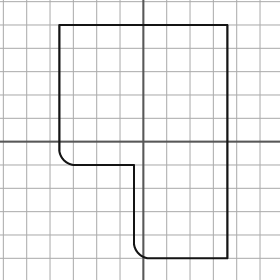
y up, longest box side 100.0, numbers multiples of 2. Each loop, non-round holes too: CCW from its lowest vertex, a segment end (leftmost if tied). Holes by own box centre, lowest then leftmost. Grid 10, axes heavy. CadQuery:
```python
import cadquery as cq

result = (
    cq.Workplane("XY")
    .moveTo(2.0, -50.0)
    .lineTo(36.0, -50.0)
    .lineTo(36.0, 50.0)
    .lineTo(-36.0, 50.0)
    .lineTo(-36.0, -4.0)
    .threePointArc((-34.0, -8.0), (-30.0, -10.0))
    .lineTo(-4.0, -10.0)
    .lineTo(-4.0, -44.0)
    .threePointArc((-2.0, -48.0), (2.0, -50.0))
    .close()
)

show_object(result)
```